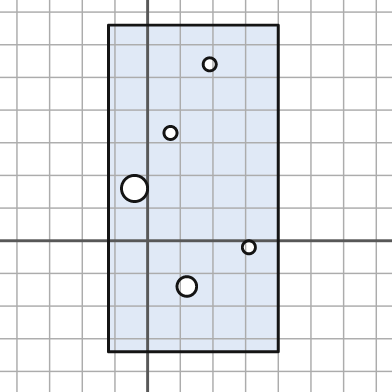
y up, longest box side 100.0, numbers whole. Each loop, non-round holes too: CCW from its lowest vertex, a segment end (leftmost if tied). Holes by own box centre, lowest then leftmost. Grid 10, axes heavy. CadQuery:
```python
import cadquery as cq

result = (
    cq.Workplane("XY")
    .moveTo(-12.0, -34.0)
    .lineTo(40.0, -34.0)
    .lineTo(40.0, 66.0)
    .lineTo(-12.0, 66.0)
    .close()
    .moveTo(12.0, -14.0)
    .circle(3.0)
    .moveTo(31.0, -2.0)
    .circle(2.0)
    .moveTo(-4.0, 16.0)
    .circle(4.0)
    .moveTo(7.0, 33.0)
    .circle(2.0)
    .moveTo(19.0, 54.0)
    .circle(2.0)
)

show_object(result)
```